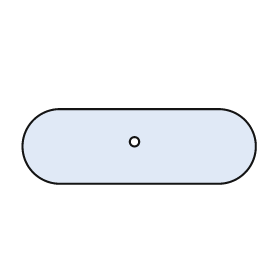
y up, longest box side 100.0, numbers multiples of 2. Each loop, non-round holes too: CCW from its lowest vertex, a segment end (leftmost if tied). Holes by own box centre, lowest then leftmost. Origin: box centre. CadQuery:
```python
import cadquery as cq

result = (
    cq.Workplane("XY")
    .moveTo(-34.0, -16.0)
    .lineTo(34.0, -16.0)
    .threePointArc((50.0, 0.0), (34.0, 16.0))
    .lineTo(-34.0, 16.0)
    .threePointArc((-50.0, 0.0), (-34.0, -16.0))
    .close()
    .moveTo(-2.0, 2.0)
    .circle(2.0)
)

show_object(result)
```